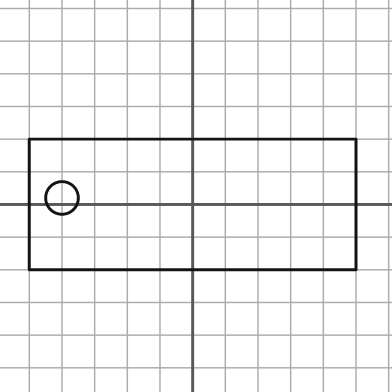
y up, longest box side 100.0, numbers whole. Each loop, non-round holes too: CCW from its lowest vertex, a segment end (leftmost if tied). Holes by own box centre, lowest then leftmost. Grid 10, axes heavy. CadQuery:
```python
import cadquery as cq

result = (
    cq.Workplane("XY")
    .moveTo(-50.0, -20.0)
    .lineTo(50.0, -20.0)
    .lineTo(50.0, 20.0)
    .lineTo(-50.0, 20.0)
    .close()
    .moveTo(-40.0, 2.0)
    .circle(5.0)
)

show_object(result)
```